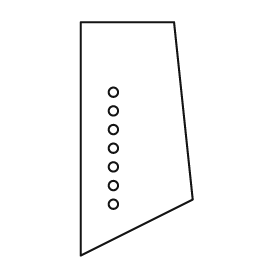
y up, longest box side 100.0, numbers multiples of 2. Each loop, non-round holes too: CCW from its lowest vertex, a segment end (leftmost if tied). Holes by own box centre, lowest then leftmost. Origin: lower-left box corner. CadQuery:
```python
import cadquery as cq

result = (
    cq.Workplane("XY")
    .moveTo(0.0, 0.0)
    .lineTo(48.0, 24.0)
    .lineTo(40.0, 100.0)
    .lineTo(0.0, 100.0)
    .close()
    .moveTo(14.0, 22.0)
    .circle(2.0)
    .moveTo(14.0, 30.0)
    .circle(2.0)
    .moveTo(14.0, 38.0)
    .circle(2.0)
    .moveTo(14.0, 46.0)
    .circle(2.0)
    .moveTo(14.0, 54.0)
    .circle(2.0)
    .moveTo(14.0, 62.0)
    .circle(2.0)
    .moveTo(14.0, 70.0)
    .circle(2.0)
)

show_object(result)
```